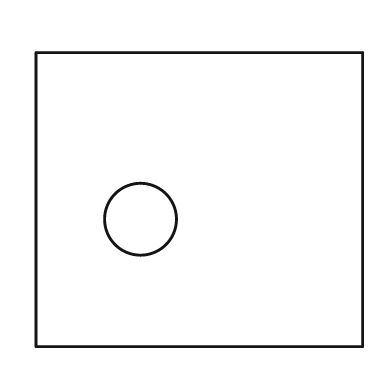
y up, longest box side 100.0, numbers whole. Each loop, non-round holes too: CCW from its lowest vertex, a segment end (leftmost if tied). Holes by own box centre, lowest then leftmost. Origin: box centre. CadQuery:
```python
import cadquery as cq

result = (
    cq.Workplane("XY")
    .moveTo(-50.0, -45.0)
    .lineTo(50.0, -45.0)
    .lineTo(50.0, 45.0)
    .lineTo(-50.0, 45.0)
    .close()
    .moveTo(-18.0, -6.0)
    .circle(11.0)
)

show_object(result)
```